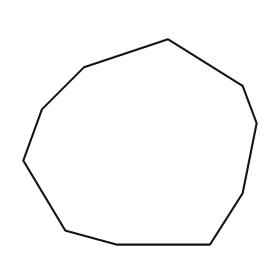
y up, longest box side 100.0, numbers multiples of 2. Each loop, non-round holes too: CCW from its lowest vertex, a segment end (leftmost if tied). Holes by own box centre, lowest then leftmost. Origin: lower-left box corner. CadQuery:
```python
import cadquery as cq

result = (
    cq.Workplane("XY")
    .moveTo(40.0, 0.0)
    .lineTo(80.0, 0.0)
    .lineTo(94.0, 22.0)
    .lineTo(100.0, 52.0)
    .lineTo(94.0, 68.0)
    .lineTo(62.0, 88.0)
    .lineTo(26.0, 76.0)
    .lineTo(8.0, 58.0)
    .lineTo(0.0, 36.0)
    .lineTo(18.0, 6.0)
    .close()
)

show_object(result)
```